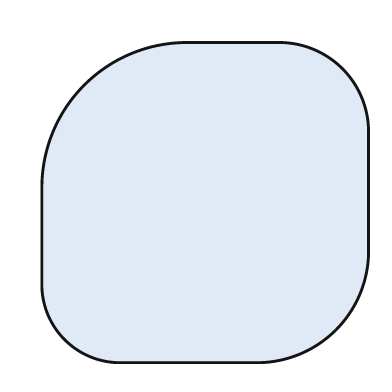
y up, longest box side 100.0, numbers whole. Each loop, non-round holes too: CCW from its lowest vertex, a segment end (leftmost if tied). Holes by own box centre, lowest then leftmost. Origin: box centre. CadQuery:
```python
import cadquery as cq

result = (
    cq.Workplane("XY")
    .moveTo(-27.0, -49.0)
    .lineTo(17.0, -49.0)
    .threePointArc((40.0, -39.0), (50.0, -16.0))
    .lineTo(50.0, 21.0)
    .threePointArc((42.0, 41.0), (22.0, 49.0))
    .lineTo(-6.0, 49.0)
    .threePointArc((-37.0, 36.0), (-50.0, 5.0))
    .lineTo(-50.0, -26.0)
    .threePointArc((-43.0, -42.0), (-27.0, -49.0))
    .close()
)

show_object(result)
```